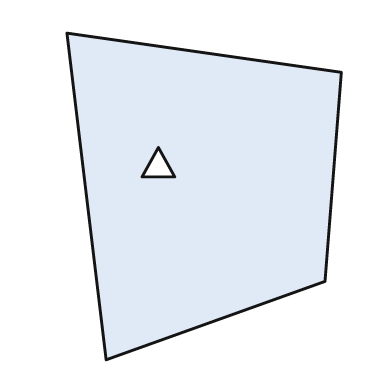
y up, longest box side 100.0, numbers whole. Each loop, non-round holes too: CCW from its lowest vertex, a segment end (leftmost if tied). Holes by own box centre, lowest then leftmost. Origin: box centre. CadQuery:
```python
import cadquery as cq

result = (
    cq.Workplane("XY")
    .moveTo(-30.0, -50.0)
    .lineTo(37.0, -26.0)
    .lineTo(42.0, 38.0)
    .lineTo(-42.0, 50.0)
    .close()
    .moveTo(-19.0, 6.0)
    .lineTo(-9.0, 6.0)
    .lineTo(-14.0, 15.0)
    .close()
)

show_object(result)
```